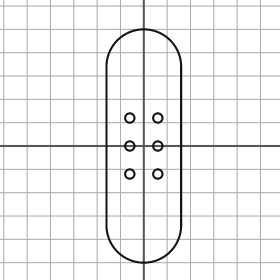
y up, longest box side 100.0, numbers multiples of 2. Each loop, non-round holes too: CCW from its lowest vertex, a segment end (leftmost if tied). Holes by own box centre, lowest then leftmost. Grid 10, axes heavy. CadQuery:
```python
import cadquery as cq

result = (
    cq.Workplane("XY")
    .moveTo(-16.0, -34.0)
    .threePointArc((0.0, -50.0), (16.0, -34.0))
    .lineTo(16.0, 34.0)
    .threePointArc((0.0, 50.0), (-16.0, 34.0))
    .close()
    .moveTo(-6.0, -12.0)
    .circle(2.0)
    .moveTo(6.0, -12.0)
    .circle(2.0)
    .moveTo(-6.0, 0.0)
    .circle(2.0)
    .moveTo(6.0, 0.0)
    .circle(2.0)
    .moveTo(-6.0, 12.0)
    .circle(2.0)
    .moveTo(6.0, 12.0)
    .circle(2.0)
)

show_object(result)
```